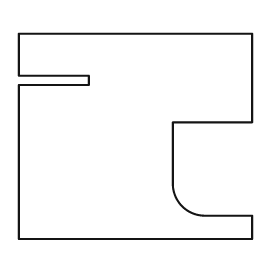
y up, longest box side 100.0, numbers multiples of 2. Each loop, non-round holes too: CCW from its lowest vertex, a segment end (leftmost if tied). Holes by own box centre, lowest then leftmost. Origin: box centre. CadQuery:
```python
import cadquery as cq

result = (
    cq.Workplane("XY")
    .moveTo(-50.0, -44.0)
    .lineTo(50.0, -44.0)
    .lineTo(50.0, -34.0)
    .lineTo(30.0, -34.0)
    .threePointArc((20.0, -30.0), (16.0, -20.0))
    .lineTo(16.0, 6.0)
    .lineTo(50.0, 6.0)
    .lineTo(50.0, 44.0)
    .lineTo(-50.0, 44.0)
    .lineTo(-50.0, 26.0)
    .lineTo(-20.0, 26.0)
    .lineTo(-20.0, 22.0)
    .lineTo(-50.0, 22.0)
    .close()
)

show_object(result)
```